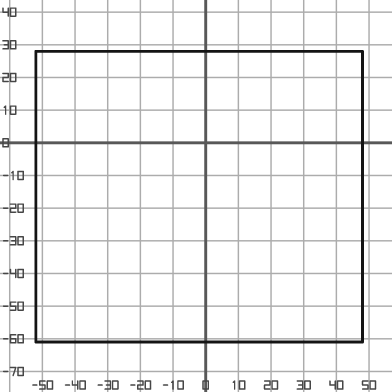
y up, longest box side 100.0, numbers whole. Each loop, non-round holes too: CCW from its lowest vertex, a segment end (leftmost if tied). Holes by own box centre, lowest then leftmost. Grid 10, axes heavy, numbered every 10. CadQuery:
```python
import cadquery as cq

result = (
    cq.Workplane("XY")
    .moveTo(-52.0, -61.0)
    .lineTo(48.0, -61.0)
    .lineTo(48.0, 28.0)
    .lineTo(-52.0, 28.0)
    .close()
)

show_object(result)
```